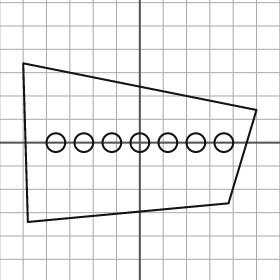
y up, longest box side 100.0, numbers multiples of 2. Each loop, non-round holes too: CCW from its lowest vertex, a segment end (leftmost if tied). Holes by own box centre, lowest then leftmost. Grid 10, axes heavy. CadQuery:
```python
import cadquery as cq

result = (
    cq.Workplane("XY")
    .moveTo(-48.0, -34.0)
    .lineTo(38.0, -26.0)
    .lineTo(50.0, 14.0)
    .lineTo(-50.0, 34.0)
    .close()
    .moveTo(-36.0, 0.0)
    .circle(4.0)
    .moveTo(-24.0, 0.0)
    .circle(4.0)
    .moveTo(-12.0, 0.0)
    .circle(4.0)
    .moveTo(0.0, 0.0)
    .circle(4.0)
    .moveTo(12.0, 0.0)
    .circle(4.0)
    .moveTo(24.0, 0.0)
    .circle(4.0)
    .moveTo(36.0, 0.0)
    .circle(4.0)
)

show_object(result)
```